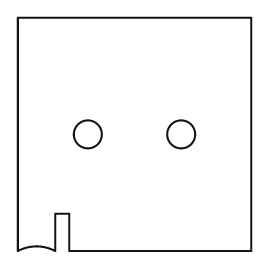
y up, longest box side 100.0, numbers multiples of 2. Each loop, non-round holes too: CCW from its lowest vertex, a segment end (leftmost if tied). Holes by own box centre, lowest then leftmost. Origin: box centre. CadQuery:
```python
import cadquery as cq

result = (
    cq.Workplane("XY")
    .moveTo(-50.0, -50.0)
    .threePointArc((-42.0, -48.0), (-34.0, -50.0))
    .lineTo(-34.0, -34.0)
    .lineTo(-28.0, -34.0)
    .lineTo(-28.0, -50.0)
    .lineTo(50.0, -50.0)
    .lineTo(50.0, 50.0)
    .lineTo(-50.0, 50.0)
    .close()
    .moveTo(-20.0, 0.0)
    .circle(6.0)
    .moveTo(20.0, 0.0)
    .circle(6.0)
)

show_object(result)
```